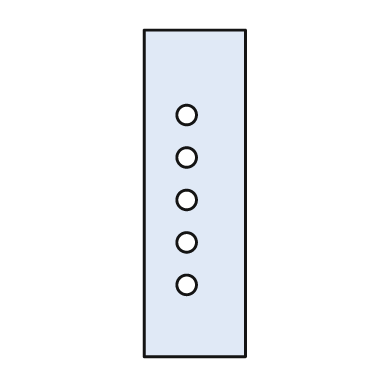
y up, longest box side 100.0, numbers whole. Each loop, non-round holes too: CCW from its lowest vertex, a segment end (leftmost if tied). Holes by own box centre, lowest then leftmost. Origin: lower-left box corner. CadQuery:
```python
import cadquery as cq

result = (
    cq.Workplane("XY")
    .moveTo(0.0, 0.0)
    .lineTo(31.0, 0.0)
    .lineTo(31.0, 100.0)
    .lineTo(0.0, 100.0)
    .close()
    .moveTo(13.0, 22.0)
    .circle(3.0)
    .moveTo(13.0, 35.0)
    .circle(3.0)
    .moveTo(13.0, 48.0)
    .circle(3.0)
    .moveTo(13.0, 61.0)
    .circle(3.0)
    .moveTo(13.0, 74.0)
    .circle(3.0)
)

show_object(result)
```